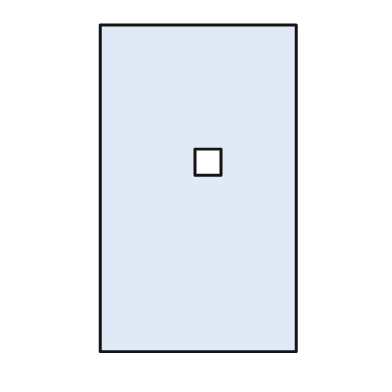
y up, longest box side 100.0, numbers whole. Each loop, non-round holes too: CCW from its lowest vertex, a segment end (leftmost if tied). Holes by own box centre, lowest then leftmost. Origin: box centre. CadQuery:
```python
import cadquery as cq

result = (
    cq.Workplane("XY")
    .moveTo(-30.0, -50.0)
    .lineTo(30.0, -50.0)
    .lineTo(30.0, 50.0)
    .lineTo(-30.0, 50.0)
    .close()
    .moveTo(-1.0, 4.0)
    .lineTo(7.0, 4.0)
    .lineTo(7.0, 12.0)
    .lineTo(-1.0, 12.0)
    .close()
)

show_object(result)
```